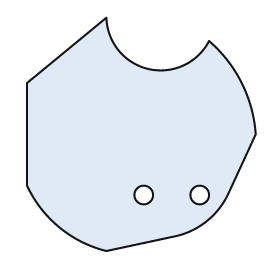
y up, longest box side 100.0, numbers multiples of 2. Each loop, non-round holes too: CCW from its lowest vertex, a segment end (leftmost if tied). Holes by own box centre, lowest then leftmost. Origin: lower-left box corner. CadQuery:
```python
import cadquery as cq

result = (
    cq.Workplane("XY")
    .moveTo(34.0, 0.0)
    .lineTo(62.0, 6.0)
    .threePointArc((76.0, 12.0), (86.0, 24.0))
    .lineTo(98.0, 50.0)
    .threePointArc((92.0, 72.0), (78.0, 90.0))
    .threePointArc((52.0, 78.0), (34.0, 100.0))
    .lineTo(0.0, 72.0)
    .lineTo(0.0, 28.0)
    .threePointArc((14.0, 10.0), (34.0, 0.0))
    .close()
    .moveTo(50.0, 24.0)
    .circle(4.0)
    .moveTo(74.0, 24.0)
    .circle(4.0)
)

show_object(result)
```